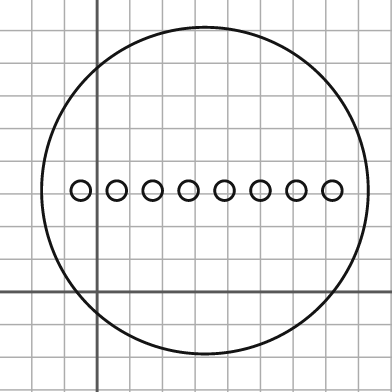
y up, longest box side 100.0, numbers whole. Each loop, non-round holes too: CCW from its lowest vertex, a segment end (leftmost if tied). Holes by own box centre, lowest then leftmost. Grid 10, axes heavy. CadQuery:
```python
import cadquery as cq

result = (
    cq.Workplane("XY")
    .moveTo(33.0, 31.0)
    .circle(50.0)
    .moveTo(-5.0, 31.0)
    .circle(3.0)
    .moveTo(6.0, 31.0)
    .circle(3.0)
    .moveTo(17.0, 31.0)
    .circle(3.0)
    .moveTo(28.0, 31.0)
    .circle(3.0)
    .moveTo(39.0, 31.0)
    .circle(3.0)
    .moveTo(50.0, 31.0)
    .circle(3.0)
    .moveTo(61.0, 31.0)
    .circle(3.0)
    .moveTo(72.0, 31.0)
    .circle(3.0)
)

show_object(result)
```